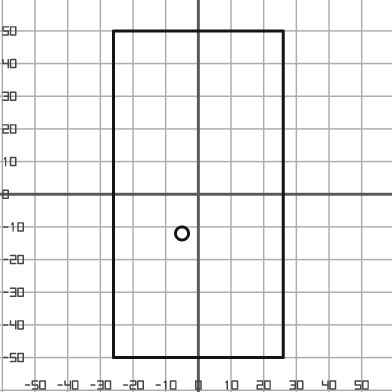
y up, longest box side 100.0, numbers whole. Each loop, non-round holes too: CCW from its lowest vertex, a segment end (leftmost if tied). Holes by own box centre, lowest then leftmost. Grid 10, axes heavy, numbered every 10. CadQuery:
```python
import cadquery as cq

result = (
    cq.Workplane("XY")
    .moveTo(-26.0, -50.0)
    .lineTo(26.0, -50.0)
    .lineTo(26.0, 50.0)
    .lineTo(-26.0, 50.0)
    .close()
    .moveTo(-5.0, -12.0)
    .circle(2.0)
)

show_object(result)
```